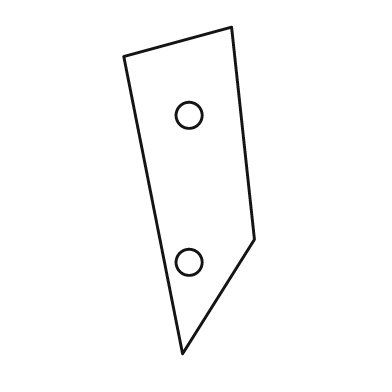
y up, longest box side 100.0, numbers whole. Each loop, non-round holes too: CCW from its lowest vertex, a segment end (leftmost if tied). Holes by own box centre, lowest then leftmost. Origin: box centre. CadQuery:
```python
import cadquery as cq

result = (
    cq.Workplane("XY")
    .moveTo(-2.0, -50.0)
    .lineTo(20.0, -15.0)
    .lineTo(13.0, 50.0)
    .lineTo(-20.0, 41.0)
    .close()
    .moveTo(0.0, -22.0)
    .circle(4.0)
    .moveTo(0.0, 23.0)
    .circle(4.0)
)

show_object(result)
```